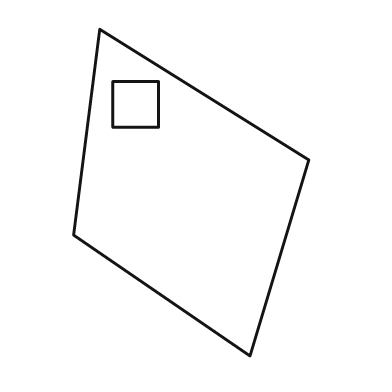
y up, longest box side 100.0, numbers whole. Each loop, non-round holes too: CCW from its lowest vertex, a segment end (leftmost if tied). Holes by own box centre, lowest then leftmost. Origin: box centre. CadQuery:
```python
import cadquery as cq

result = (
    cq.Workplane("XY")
    .moveTo(18.0, -50.0)
    .lineTo(36.0, 10.0)
    .lineTo(-28.0, 50.0)
    .lineTo(-36.0, -13.0)
    .close()
    .moveTo(-24.0, 20.0)
    .lineTo(-10.0, 20.0)
    .lineTo(-10.0, 34.0)
    .lineTo(-24.0, 34.0)
    .close()
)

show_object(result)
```